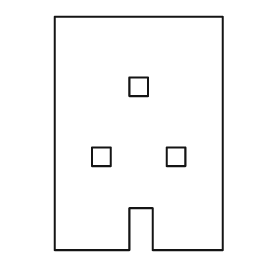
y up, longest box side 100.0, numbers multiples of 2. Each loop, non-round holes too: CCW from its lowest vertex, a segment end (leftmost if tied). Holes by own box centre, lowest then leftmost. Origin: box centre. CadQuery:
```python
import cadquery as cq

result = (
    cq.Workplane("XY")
    .moveTo(-36.0, -50.0)
    .lineTo(-4.0, -50.0)
    .lineTo(-4.0, -32.0)
    .lineTo(6.0, -32.0)
    .lineTo(6.0, -50.0)
    .lineTo(36.0, -50.0)
    .lineTo(36.0, 50.0)
    .lineTo(-36.0, 50.0)
    .close()
    .moveTo(-20.0, -14.0)
    .lineTo(-12.0, -14.0)
    .lineTo(-12.0, -6.0)
    .lineTo(-20.0, -6.0)
    .close()
    .moveTo(12.0, -14.0)
    .lineTo(20.0, -14.0)
    .lineTo(20.0, -6.0)
    .lineTo(12.0, -6.0)
    .close()
    .moveTo(-4.0, 16.0)
    .lineTo(4.0, 16.0)
    .lineTo(4.0, 24.0)
    .lineTo(-4.0, 24.0)
    .close()
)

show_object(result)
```